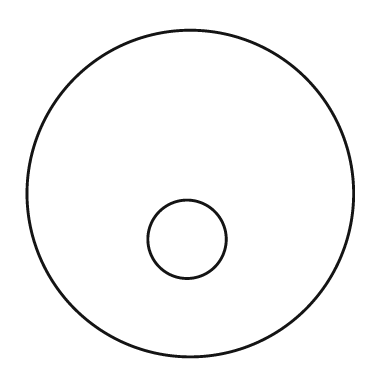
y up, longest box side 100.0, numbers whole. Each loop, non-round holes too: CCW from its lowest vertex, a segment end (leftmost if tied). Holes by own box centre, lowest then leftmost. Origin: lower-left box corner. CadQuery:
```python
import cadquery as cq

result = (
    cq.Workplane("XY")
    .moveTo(50.0, 50.0)
    .circle(50.0)
    .moveTo(49.0, 36.0)
    .circle(12.0)
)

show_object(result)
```